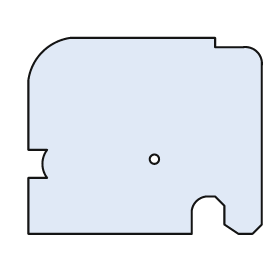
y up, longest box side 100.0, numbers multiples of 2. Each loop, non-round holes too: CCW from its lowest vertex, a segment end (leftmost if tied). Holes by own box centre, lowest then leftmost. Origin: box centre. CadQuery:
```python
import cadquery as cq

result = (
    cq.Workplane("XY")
    .moveTo(-50.0, -42.0)
    .lineTo(20.0, -42.0)
    .lineTo(20.0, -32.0)
    .threePointArc((22.0, -28.0), (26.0, -26.0))
    .lineTo(30.0, -26.0)
    .lineTo(34.0, -30.0)
    .lineTo(34.0, -38.0)
    .lineTo(40.0, -42.0)
    .lineTo(46.0, -42.0)
    .lineTo(50.0, -38.0)
    .lineTo(50.0, 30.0)
    .threePointArc((48.0, 36.0), (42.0, 38.0))
    .lineTo(30.0, 38.0)
    .lineTo(30.0, 42.0)
    .lineTo(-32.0, 42.0)
    .threePointArc((-44.0, 36.0), (-50.0, 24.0))
    .lineTo(-50.0, -6.0)
    .lineTo(-42.0, -6.0)
    .threePointArc((-44.0, -12.0), (-42.0, -18.0))
    .lineTo(-50.0, -18.0)
    .close()
    .moveTo(4.0, -10.0)
    .circle(2.0)
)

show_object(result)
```